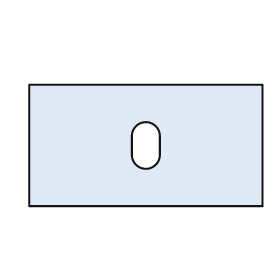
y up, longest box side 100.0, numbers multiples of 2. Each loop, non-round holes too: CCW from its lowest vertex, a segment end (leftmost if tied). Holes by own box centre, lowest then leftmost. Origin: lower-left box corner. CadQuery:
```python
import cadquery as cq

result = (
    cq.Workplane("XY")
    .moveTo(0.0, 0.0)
    .lineTo(100.0, 0.0)
    .lineTo(100.0, 52.0)
    .lineTo(0.0, 52.0)
    .close()
    .moveTo(44.0, 22.0)
    .threePointArc((50.0, 16.0), (56.0, 22.0))
    .lineTo(56.0, 30.0)
    .threePointArc((50.0, 36.0), (44.0, 30.0))
    .close()
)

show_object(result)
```